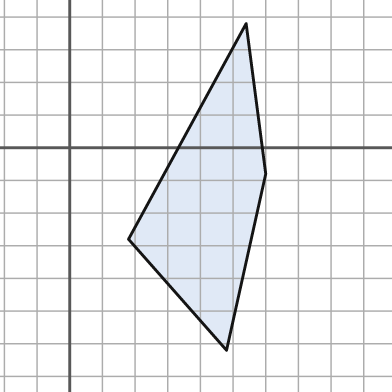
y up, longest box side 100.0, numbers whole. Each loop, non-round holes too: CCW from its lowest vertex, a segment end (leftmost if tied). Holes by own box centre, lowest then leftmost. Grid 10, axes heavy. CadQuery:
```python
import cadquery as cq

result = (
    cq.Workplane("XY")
    .moveTo(48.0, -62.0)
    .lineTo(60.0, -8.0)
    .lineTo(54.0, 38.0)
    .lineTo(18.0, -28.0)
    .close()
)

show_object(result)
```